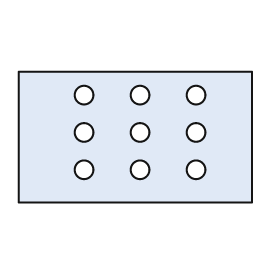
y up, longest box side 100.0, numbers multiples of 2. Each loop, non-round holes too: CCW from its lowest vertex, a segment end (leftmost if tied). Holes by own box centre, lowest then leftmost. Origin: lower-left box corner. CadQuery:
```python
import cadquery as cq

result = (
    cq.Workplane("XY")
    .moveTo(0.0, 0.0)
    .lineTo(100.0, 0.0)
    .lineTo(100.0, 56.0)
    .lineTo(0.0, 56.0)
    .close()
    .moveTo(28.0, 14.0)
    .circle(4.0)
    .moveTo(52.0, 14.0)
    .circle(4.0)
    .moveTo(76.0, 14.0)
    .circle(4.0)
    .moveTo(28.0, 30.0)
    .circle(4.0)
    .moveTo(52.0, 30.0)
    .circle(4.0)
    .moveTo(76.0, 30.0)
    .circle(4.0)
    .moveTo(28.0, 46.0)
    .circle(4.0)
    .moveTo(52.0, 46.0)
    .circle(4.0)
    .moveTo(76.0, 46.0)
    .circle(4.0)
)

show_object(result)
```